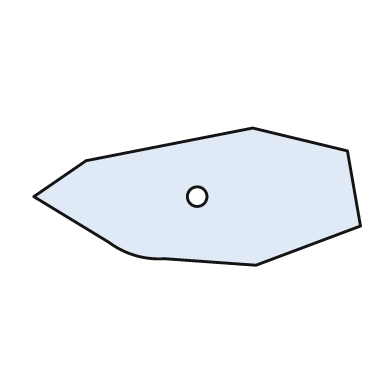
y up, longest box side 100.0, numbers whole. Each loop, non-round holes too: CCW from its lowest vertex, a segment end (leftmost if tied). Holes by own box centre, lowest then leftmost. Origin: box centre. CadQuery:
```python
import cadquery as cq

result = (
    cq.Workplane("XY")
    .moveTo(18.0, -21.0)
    .lineTo(50.0, -9.0)
    .lineTo(46.0, 14.0)
    .lineTo(17.0, 21.0)
    .lineTo(-34.0, 11.0)
    .lineTo(-50.0, 0.0)
    .lineTo(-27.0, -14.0)
    .threePointArc((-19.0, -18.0), (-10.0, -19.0))
    .close()
    .moveTo(0.0, 0.0)
    .circle(3.0)
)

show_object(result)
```